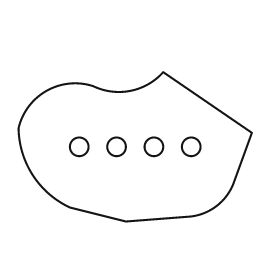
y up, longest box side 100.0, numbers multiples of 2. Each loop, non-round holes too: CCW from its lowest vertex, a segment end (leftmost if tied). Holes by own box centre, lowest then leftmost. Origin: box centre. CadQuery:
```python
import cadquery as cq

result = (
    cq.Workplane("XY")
    .moveTo(-4.0, -32.0)
    .lineTo(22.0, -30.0)
    .threePointArc((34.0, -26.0), (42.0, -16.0))
    .lineTo(50.0, 6.0)
    .lineTo(12.0, 32.0)
    .threePointArc((-2.0, 24.0), (-18.0, 26.0))
    .threePointArc((-38.0, 24.0), (-50.0, 8.0))
    .threePointArc((-44.0, -12.0), (-28.0, -26.0))
    .close()
    .moveTo(-24.0, 0.0)
    .circle(4.0)
    .moveTo(-8.0, 0.0)
    .circle(4.0)
    .moveTo(8.0, 0.0)
    .circle(4.0)
    .moveTo(24.0, 0.0)
    .circle(4.0)
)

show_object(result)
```